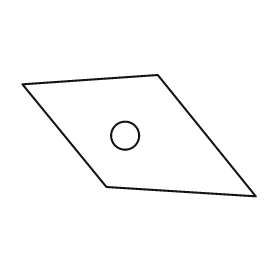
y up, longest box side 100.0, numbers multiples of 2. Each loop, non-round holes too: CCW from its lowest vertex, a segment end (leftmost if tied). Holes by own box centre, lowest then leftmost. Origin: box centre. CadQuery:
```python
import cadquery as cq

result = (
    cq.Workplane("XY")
    .moveTo(50.0, -26.0)
    .lineTo(8.0, 26.0)
    .lineTo(-50.0, 22.0)
    .lineTo(-14.0, -22.0)
    .close()
    .moveTo(-6.0, 0.0)
    .circle(6.0)
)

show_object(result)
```